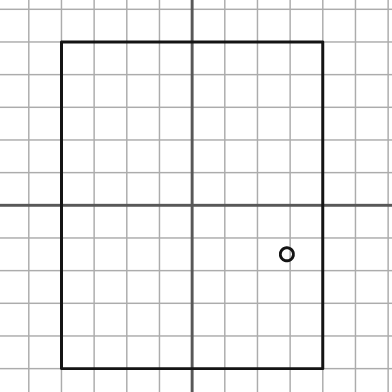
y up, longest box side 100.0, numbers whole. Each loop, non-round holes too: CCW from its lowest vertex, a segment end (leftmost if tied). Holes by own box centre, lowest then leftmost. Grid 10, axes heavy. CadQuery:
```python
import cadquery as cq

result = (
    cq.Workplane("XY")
    .moveTo(-40.0, -50.0)
    .lineTo(40.0, -50.0)
    .lineTo(40.0, 50.0)
    .lineTo(-40.0, 50.0)
    .close()
    .moveTo(29.0, -15.0)
    .circle(2.0)
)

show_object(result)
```